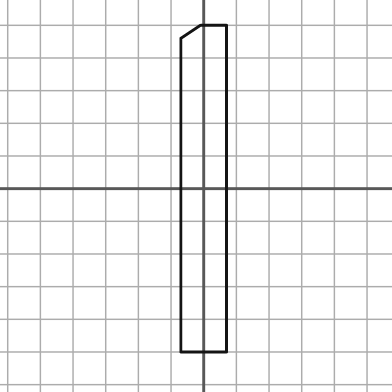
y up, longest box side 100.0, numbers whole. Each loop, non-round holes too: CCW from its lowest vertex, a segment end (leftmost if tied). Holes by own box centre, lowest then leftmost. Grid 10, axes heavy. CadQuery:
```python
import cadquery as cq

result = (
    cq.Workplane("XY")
    .moveTo(-7.0, -50.0)
    .lineTo(7.0, -50.0)
    .lineTo(7.0, 50.0)
    .lineTo(-1.0, 50.0)
    .lineTo(-7.0, 46.0)
    .close()
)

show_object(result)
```